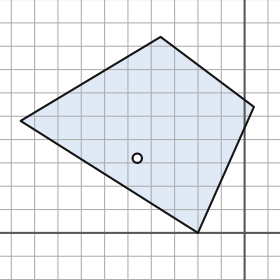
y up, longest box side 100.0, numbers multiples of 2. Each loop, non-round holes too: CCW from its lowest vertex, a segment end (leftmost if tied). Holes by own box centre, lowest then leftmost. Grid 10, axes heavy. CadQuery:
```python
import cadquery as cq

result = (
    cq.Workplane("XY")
    .moveTo(-20.0, 0.0)
    .lineTo(4.0, 54.0)
    .lineTo(-36.0, 84.0)
    .lineTo(-96.0, 48.0)
    .close()
    .moveTo(-46.0, 32.0)
    .circle(2.0)
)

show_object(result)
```